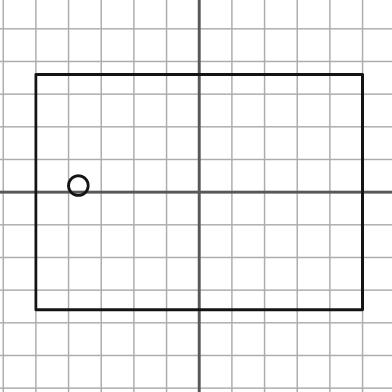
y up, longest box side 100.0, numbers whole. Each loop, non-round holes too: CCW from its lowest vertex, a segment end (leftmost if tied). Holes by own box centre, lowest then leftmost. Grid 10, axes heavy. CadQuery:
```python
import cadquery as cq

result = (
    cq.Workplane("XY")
    .moveTo(-50.0, -36.0)
    .lineTo(50.0, -36.0)
    .lineTo(50.0, 36.0)
    .lineTo(-50.0, 36.0)
    .close()
    .moveTo(-37.0, 2.0)
    .circle(3.0)
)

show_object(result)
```